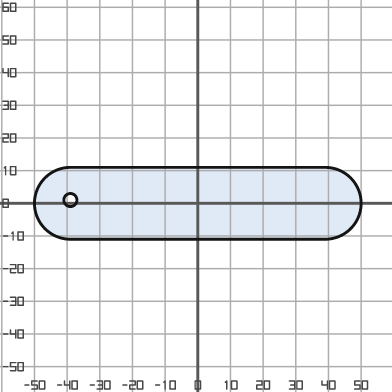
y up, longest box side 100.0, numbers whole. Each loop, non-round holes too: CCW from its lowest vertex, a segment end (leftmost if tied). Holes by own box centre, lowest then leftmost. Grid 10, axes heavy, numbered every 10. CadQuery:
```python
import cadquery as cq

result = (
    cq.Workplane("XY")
    .moveTo(-39.0, -11.0)
    .lineTo(39.0, -11.0)
    .threePointArc((50.0, 0.0), (39.0, 11.0))
    .lineTo(-39.0, 11.0)
    .threePointArc((-50.0, 0.0), (-39.0, -11.0))
    .close()
    .moveTo(-39.0, 1.0)
    .circle(2.0)
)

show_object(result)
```